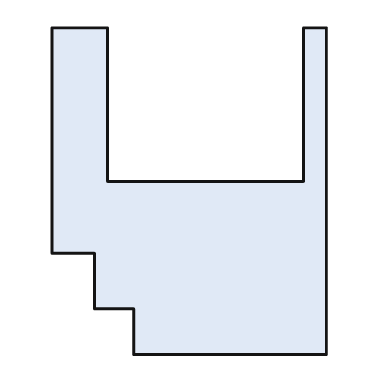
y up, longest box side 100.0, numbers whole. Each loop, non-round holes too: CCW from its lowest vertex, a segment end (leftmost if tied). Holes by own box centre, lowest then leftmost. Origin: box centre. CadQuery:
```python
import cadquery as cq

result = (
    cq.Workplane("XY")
    .moveTo(-17.0, -50.0)
    .lineTo(42.0, -50.0)
    .lineTo(42.0, 50.0)
    .lineTo(35.0, 50.0)
    .lineTo(35.0, 3.0)
    .lineTo(-25.0, 3.0)
    .lineTo(-25.0, 50.0)
    .lineTo(-42.0, 50.0)
    .lineTo(-42.0, -19.0)
    .lineTo(-29.0, -19.0)
    .lineTo(-29.0, -36.0)
    .lineTo(-17.0, -36.0)
    .close()
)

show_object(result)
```